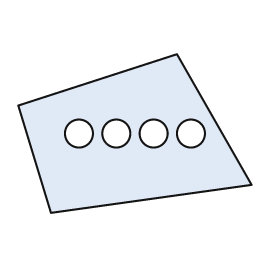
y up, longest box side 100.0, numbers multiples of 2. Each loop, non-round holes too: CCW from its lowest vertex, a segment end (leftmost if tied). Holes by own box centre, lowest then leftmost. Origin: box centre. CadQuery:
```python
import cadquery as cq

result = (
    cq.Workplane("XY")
    .moveTo(-36.0, -34.0)
    .lineTo(50.0, -22.0)
    .lineTo(18.0, 34.0)
    .lineTo(-50.0, 12.0)
    .close()
    .moveTo(-24.0, 0.0)
    .circle(6.0)
    .moveTo(-8.0, 0.0)
    .circle(6.0)
    .moveTo(8.0, 0.0)
    .circle(6.0)
    .moveTo(24.0, 0.0)
    .circle(6.0)
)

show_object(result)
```